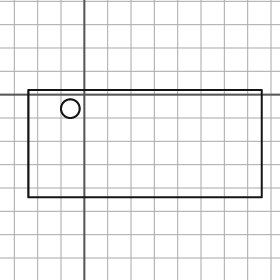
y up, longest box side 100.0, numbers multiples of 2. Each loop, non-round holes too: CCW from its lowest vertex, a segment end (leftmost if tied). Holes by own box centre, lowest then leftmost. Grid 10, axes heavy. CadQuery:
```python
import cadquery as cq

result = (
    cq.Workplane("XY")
    .moveTo(-24.0, -44.0)
    .lineTo(76.0, -44.0)
    .lineTo(76.0, 2.0)
    .lineTo(-24.0, 2.0)
    .close()
    .moveTo(-6.0, -6.0)
    .circle(4.0)
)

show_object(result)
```